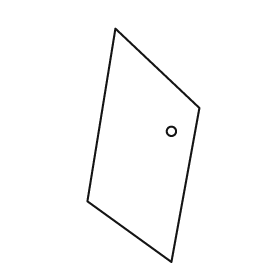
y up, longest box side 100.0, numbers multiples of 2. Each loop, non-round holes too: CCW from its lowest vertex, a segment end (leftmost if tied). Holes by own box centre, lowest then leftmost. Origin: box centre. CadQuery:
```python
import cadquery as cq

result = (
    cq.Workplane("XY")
    .moveTo(12.0, -50.0)
    .lineTo(24.0, 16.0)
    .lineTo(-12.0, 50.0)
    .lineTo(-24.0, -24.0)
    .close()
    .moveTo(12.0, 6.0)
    .circle(2.0)
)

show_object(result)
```